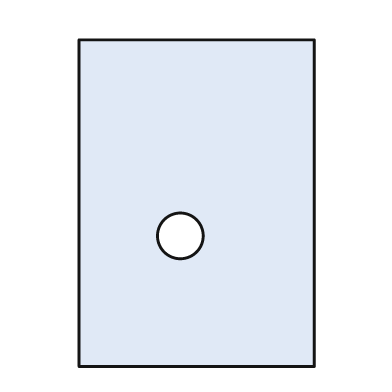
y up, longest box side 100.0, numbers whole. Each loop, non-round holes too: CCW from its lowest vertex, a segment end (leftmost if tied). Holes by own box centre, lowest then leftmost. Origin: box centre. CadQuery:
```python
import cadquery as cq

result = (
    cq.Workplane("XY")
    .moveTo(-36.0, -50.0)
    .lineTo(36.0, -50.0)
    .lineTo(36.0, 50.0)
    .lineTo(-36.0, 50.0)
    .close()
    .moveTo(-5.0, -10.0)
    .circle(7.0)
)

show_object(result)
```